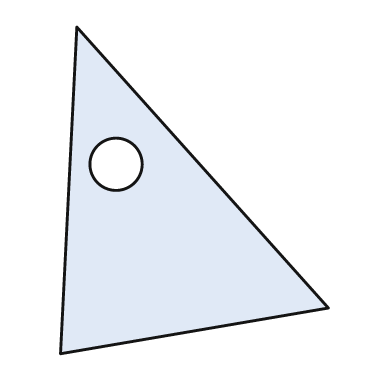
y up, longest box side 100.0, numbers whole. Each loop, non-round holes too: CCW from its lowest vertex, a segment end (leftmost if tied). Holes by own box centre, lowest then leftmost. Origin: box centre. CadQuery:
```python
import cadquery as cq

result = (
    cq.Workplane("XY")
    .moveTo(-41.0, -50.0)
    .lineTo(41.0, -36.0)
    .lineTo(-36.0, 50.0)
    .close()
    .moveTo(-24.0, 8.0)
    .circle(8.0)
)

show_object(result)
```